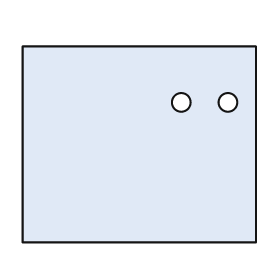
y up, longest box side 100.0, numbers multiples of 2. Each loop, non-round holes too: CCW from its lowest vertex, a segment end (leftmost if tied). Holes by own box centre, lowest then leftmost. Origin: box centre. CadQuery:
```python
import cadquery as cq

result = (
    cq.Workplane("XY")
    .moveTo(-50.0, -42.0)
    .lineTo(50.0, -42.0)
    .lineTo(50.0, 42.0)
    .lineTo(-50.0, 42.0)
    .close()
    .moveTo(18.0, 18.0)
    .circle(4.0)
    .moveTo(38.0, 18.0)
    .circle(4.0)
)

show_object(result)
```